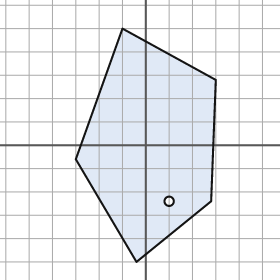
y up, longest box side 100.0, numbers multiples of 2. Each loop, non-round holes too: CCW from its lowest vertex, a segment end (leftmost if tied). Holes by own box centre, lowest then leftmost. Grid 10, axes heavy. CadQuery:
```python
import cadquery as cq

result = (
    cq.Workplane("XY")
    .moveTo(-4.0, -50.0)
    .lineTo(28.0, -24.0)
    .lineTo(30.0, 28.0)
    .lineTo(-10.0, 50.0)
    .lineTo(-30.0, -6.0)
    .close()
    .moveTo(10.0, -24.0)
    .circle(2.0)
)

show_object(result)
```